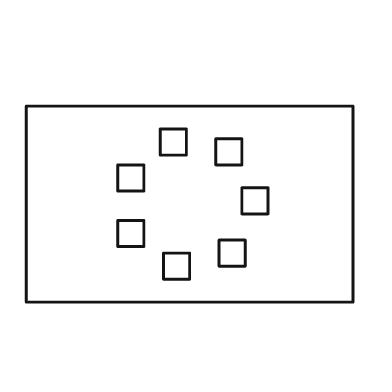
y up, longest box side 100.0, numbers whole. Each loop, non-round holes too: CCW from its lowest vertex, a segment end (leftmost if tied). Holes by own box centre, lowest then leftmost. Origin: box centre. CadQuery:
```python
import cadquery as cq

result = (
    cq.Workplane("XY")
    .moveTo(-50.0, -30.0)
    .lineTo(50.0, -30.0)
    .lineTo(50.0, 30.0)
    .lineTo(-50.0, 30.0)
    .close()
    .moveTo(-8.0, -23.0)
    .lineTo(0.0, -23.0)
    .lineTo(0.0, -15.0)
    .lineTo(-8.0, -15.0)
    .close()
    .moveTo(9.0, -19.0)
    .lineTo(17.0, -19.0)
    .lineTo(17.0, -11.0)
    .lineTo(9.0, -11.0)
    .close()
    .moveTo(-22.0, -13.0)
    .lineTo(-14.0, -13.0)
    .lineTo(-14.0, -5.0)
    .lineTo(-22.0, -5.0)
    .close()
    .moveTo(16.0, -3.0)
    .lineTo(24.0, -3.0)
    .lineTo(24.0, 5.0)
    .lineTo(16.0, 5.0)
    .close()
    .moveTo(-22.0, 4.0)
    .lineTo(-14.0, 4.0)
    .lineTo(-14.0, 12.0)
    .lineTo(-22.0, 12.0)
    .close()
    .moveTo(8.0, 12.0)
    .lineTo(16.0, 12.0)
    .lineTo(16.0, 20.0)
    .lineTo(8.0, 20.0)
    .close()
    .moveTo(-9.0, 15.0)
    .lineTo(-1.0, 15.0)
    .lineTo(-1.0, 23.0)
    .lineTo(-9.0, 23.0)
    .close()
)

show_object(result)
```